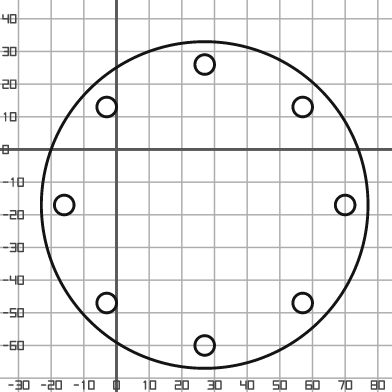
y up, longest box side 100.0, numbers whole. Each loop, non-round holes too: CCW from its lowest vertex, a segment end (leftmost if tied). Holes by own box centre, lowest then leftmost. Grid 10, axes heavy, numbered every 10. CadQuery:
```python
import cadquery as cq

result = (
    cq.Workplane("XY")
    .moveTo(27.0, -17.0)
    .circle(50.0)
    .moveTo(27.0, -60.0)
    .circle(3.0)
    .moveTo(-3.0, -47.0)
    .circle(3.0)
    .moveTo(57.0, -47.0)
    .circle(3.0)
    .moveTo(-16.0, -17.0)
    .circle(3.0)
    .moveTo(70.0, -17.0)
    .circle(3.0)
    .moveTo(-3.0, 13.0)
    .circle(3.0)
    .moveTo(57.0, 13.0)
    .circle(3.0)
    .moveTo(27.0, 26.0)
    .circle(3.0)
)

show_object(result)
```